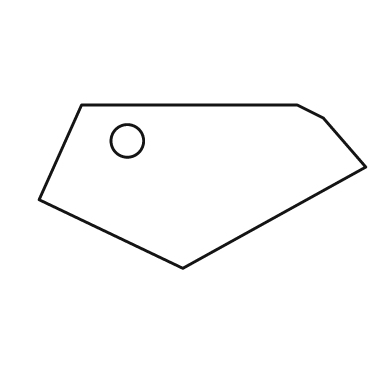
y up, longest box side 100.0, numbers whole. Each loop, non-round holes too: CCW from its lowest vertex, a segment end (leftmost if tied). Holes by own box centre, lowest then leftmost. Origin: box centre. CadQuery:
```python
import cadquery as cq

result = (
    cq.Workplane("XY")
    .moveTo(-6.0, -25.0)
    .lineTo(50.0, 6.0)
    .lineTo(37.0, 21.0)
    .lineTo(29.0, 25.0)
    .lineTo(-37.0, 25.0)
    .lineTo(-50.0, -4.0)
    .close()
    .moveTo(-23.0, 14.0)
    .circle(5.0)
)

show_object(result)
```